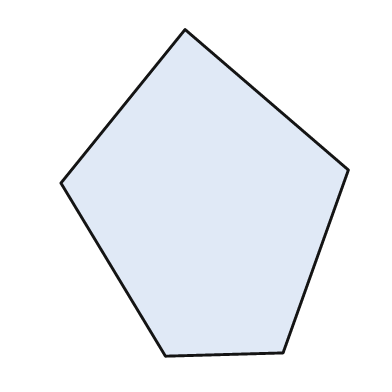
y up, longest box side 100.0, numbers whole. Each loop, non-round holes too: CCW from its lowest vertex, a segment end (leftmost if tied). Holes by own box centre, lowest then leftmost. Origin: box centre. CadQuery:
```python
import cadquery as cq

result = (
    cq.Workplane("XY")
    .moveTo(-12.0, -50.0)
    .lineTo(24.0, -49.0)
    .lineTo(44.0, 7.0)
    .lineTo(-6.0, 50.0)
    .lineTo(-44.0, 3.0)
    .close()
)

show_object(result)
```